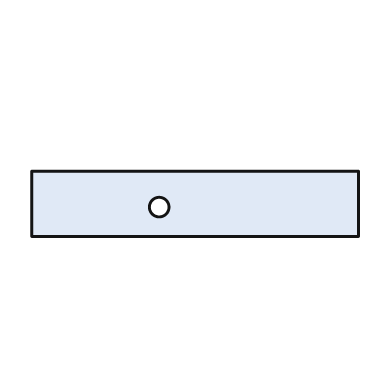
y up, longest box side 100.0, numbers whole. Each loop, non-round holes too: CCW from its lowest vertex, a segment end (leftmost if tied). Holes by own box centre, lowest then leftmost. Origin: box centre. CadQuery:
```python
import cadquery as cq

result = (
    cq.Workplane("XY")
    .moveTo(-50.0, -10.0)
    .lineTo(50.0, -10.0)
    .lineTo(50.0, 10.0)
    .lineTo(-50.0, 10.0)
    .close()
    .moveTo(-11.0, -1.0)
    .circle(3.0)
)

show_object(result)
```